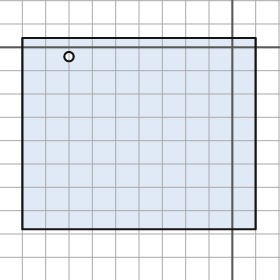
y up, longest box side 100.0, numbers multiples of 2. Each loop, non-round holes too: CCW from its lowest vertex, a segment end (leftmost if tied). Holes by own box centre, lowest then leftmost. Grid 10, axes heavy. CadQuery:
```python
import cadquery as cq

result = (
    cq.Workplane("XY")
    .moveTo(-90.0, -78.0)
    .lineTo(10.0, -78.0)
    .lineTo(10.0, 4.0)
    .lineTo(-90.0, 4.0)
    .close()
    .moveTo(-70.0, -4.0)
    .circle(2.0)
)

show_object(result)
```